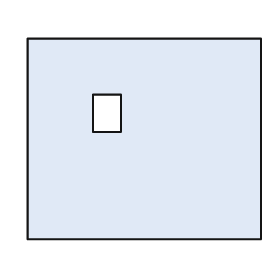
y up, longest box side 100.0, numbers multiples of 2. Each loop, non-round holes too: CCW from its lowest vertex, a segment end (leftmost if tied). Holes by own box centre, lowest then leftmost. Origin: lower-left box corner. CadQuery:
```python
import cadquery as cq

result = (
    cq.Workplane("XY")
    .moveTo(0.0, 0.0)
    .lineTo(100.0, 0.0)
    .lineTo(100.0, 86.0)
    .lineTo(0.0, 86.0)
    .close()
    .moveTo(28.0, 46.0)
    .lineTo(40.0, 46.0)
    .lineTo(40.0, 62.0)
    .lineTo(28.0, 62.0)
    .close()
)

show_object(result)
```